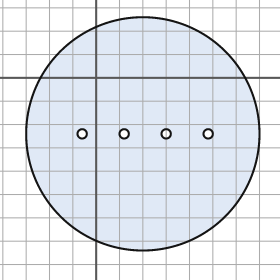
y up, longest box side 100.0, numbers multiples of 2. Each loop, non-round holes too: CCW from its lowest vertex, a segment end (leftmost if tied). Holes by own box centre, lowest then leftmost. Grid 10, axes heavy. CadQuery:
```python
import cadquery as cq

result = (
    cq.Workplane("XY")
    .moveTo(20.0, -24.0)
    .circle(50.0)
    .moveTo(-6.0, -24.0)
    .circle(2.0)
    .moveTo(12.0, -24.0)
    .circle(2.0)
    .moveTo(30.0, -24.0)
    .circle(2.0)
    .moveTo(48.0, -24.0)
    .circle(2.0)
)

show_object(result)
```